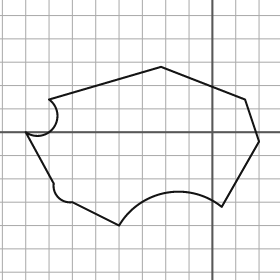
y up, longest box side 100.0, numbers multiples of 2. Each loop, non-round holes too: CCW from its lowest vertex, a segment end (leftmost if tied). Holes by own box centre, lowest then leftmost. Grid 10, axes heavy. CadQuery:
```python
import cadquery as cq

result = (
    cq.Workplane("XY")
    .moveTo(-40.0, -40.0)
    .threePointArc((-20.0, -26.0), (4.0, -32.0))
    .lineTo(20.0, -4.0)
    .lineTo(14.0, 14.0)
    .lineTo(-22.0, 28.0)
    .lineTo(-70.0, 14.0)
    .threePointArc((-68.0, 2.0), (-80.0, 0.0))
    .lineTo(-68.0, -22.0)
    .threePointArc((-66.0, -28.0), (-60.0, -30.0))
    .close()
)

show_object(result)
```